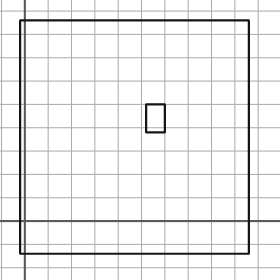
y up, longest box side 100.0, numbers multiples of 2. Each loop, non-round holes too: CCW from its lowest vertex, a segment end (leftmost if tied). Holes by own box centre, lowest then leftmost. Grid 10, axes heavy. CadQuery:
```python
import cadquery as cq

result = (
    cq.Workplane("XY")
    .moveTo(-2.0, -14.0)
    .lineTo(96.0, -14.0)
    .lineTo(96.0, 86.0)
    .lineTo(-2.0, 86.0)
    .close()
    .moveTo(52.0, 38.0)
    .lineTo(60.0, 38.0)
    .lineTo(60.0, 50.0)
    .lineTo(52.0, 50.0)
    .close()
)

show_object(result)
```